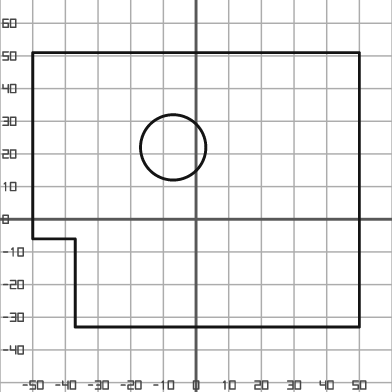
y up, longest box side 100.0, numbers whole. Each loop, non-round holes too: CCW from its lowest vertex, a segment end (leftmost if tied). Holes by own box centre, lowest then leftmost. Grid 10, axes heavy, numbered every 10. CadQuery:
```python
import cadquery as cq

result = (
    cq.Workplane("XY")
    .moveTo(-37.0, -33.0)
    .lineTo(50.0, -33.0)
    .lineTo(50.0, 51.0)
    .lineTo(-50.0, 51.0)
    .lineTo(-50.0, -6.0)
    .lineTo(-37.0, -6.0)
    .close()
    .moveTo(-7.0, 22.0)
    .circle(10.0)
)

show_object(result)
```